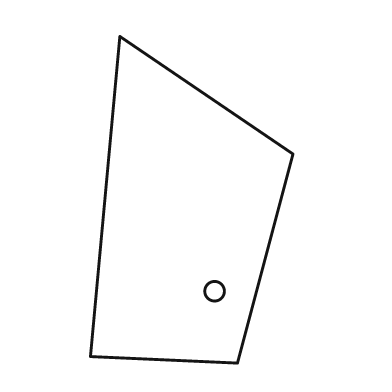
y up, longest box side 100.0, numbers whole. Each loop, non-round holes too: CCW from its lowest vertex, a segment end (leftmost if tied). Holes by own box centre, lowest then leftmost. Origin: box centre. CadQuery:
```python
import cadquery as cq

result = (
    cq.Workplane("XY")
    .moveTo(14.0, -50.0)
    .lineTo(31.0, 14.0)
    .lineTo(-22.0, 50.0)
    .lineTo(-31.0, -48.0)
    .close()
    .moveTo(7.0, -28.0)
    .circle(3.0)
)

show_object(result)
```